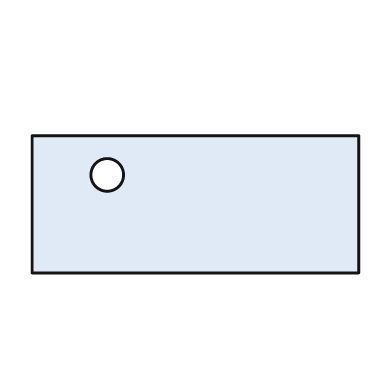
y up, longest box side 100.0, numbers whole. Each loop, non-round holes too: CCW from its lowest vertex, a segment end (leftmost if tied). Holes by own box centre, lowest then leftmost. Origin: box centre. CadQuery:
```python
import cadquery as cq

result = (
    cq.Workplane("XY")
    .moveTo(-50.0, -21.0)
    .lineTo(50.0, -21.0)
    .lineTo(50.0, 21.0)
    .lineTo(-50.0, 21.0)
    .close()
    .moveTo(-27.0, 9.0)
    .circle(5.0)
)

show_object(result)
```